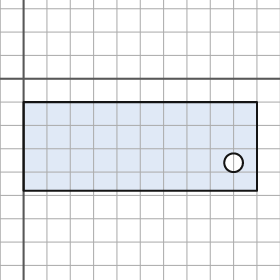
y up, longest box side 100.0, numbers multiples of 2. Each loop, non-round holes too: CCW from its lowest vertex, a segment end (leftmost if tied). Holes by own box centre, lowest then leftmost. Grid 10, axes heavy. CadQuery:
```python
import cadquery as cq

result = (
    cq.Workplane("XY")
    .moveTo(0.0, -48.0)
    .lineTo(100.0, -48.0)
    .lineTo(100.0, -10.0)
    .lineTo(0.0, -10.0)
    .close()
    .moveTo(90.0, -36.0)
    .circle(4.0)
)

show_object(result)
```